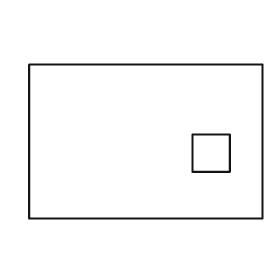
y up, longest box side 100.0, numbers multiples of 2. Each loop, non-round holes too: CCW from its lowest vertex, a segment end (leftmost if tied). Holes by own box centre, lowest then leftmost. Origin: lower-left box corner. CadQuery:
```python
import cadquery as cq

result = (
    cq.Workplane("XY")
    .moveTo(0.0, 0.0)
    .lineTo(100.0, 0.0)
    .lineTo(100.0, 66.0)
    .lineTo(0.0, 66.0)
    .close()
    .moveTo(70.0, 20.0)
    .lineTo(86.0, 20.0)
    .lineTo(86.0, 36.0)
    .lineTo(70.0, 36.0)
    .close()
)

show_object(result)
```